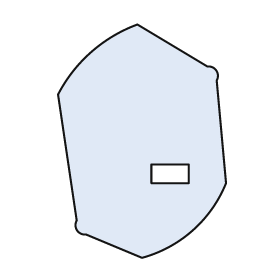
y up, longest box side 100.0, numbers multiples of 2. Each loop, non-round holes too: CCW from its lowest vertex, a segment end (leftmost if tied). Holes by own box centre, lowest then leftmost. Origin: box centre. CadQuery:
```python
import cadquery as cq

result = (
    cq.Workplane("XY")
    .moveTo(0.0, -50.0)
    .threePointArc((22.0, -38.0), (36.0, -18.0))
    .lineTo(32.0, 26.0)
    .threePointArc((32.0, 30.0), (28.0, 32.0))
    .lineTo(-2.0, 50.0)
    .threePointArc((-22.0, 38.0), (-36.0, 20.0))
    .lineTo(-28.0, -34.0)
    .threePointArc((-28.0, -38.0), (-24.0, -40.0))
    .close()
    .moveTo(4.0, -18.0)
    .lineTo(20.0, -18.0)
    .lineTo(20.0, -10.0)
    .lineTo(4.0, -10.0)
    .close()
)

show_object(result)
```